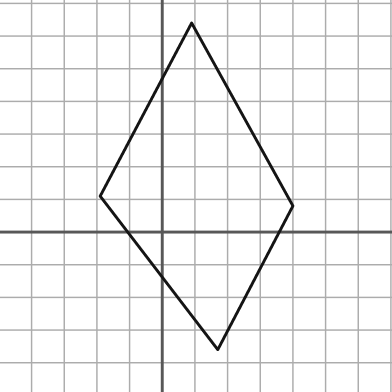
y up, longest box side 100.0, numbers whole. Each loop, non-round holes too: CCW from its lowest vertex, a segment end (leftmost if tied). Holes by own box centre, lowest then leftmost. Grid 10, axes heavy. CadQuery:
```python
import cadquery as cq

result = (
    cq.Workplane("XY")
    .moveTo(17.0, -36.0)
    .lineTo(40.0, 8.0)
    .lineTo(9.0, 64.0)
    .lineTo(-19.0, 11.0)
    .close()
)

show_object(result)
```